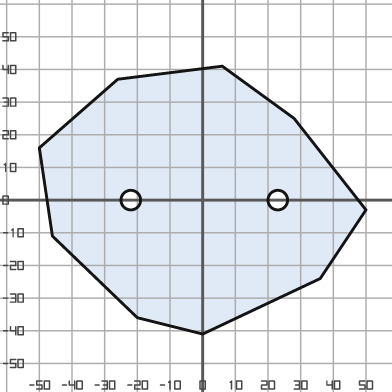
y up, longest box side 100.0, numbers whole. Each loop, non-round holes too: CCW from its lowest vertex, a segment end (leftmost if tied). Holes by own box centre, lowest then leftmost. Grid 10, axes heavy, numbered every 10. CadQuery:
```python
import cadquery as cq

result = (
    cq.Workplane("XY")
    .moveTo(0.0, -41.0)
    .lineTo(36.0, -24.0)
    .lineTo(50.0, -3.0)
    .lineTo(28.0, 25.0)
    .lineTo(6.0, 41.0)
    .lineTo(-26.0, 37.0)
    .lineTo(-50.0, 16.0)
    .lineTo(-46.0, -11.0)
    .lineTo(-20.0, -36.0)
    .close()
    .moveTo(-22.0, 0.0)
    .circle(3.0)
    .moveTo(23.0, 0.0)
    .circle(3.0)
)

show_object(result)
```